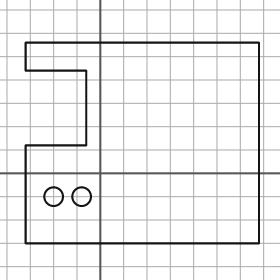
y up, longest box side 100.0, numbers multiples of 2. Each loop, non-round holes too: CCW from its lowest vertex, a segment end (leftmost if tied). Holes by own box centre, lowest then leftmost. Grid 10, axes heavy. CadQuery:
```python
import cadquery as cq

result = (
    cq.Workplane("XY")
    .moveTo(-32.0, -30.0)
    .lineTo(68.0, -30.0)
    .lineTo(68.0, 56.0)
    .lineTo(-32.0, 56.0)
    .lineTo(-32.0, 44.0)
    .lineTo(-6.0, 44.0)
    .lineTo(-6.0, 12.0)
    .lineTo(-32.0, 12.0)
    .close()
    .moveTo(-20.0, -10.0)
    .circle(4.0)
    .moveTo(-8.0, -10.0)
    .circle(4.0)
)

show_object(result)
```